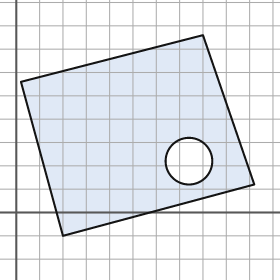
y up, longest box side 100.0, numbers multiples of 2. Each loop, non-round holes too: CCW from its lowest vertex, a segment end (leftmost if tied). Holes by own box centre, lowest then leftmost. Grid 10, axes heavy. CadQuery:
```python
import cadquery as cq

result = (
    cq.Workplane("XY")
    .moveTo(20.0, -10.0)
    .lineTo(102.0, 12.0)
    .lineTo(80.0, 76.0)
    .lineTo(2.0, 56.0)
    .close()
    .moveTo(74.0, 22.0)
    .circle(10.0)
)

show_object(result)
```